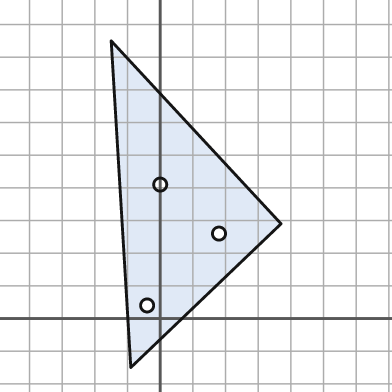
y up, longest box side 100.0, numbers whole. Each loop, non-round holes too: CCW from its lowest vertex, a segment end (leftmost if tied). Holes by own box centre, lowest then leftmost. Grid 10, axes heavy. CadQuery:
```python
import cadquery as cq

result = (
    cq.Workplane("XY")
    .moveTo(-9.0, -15.0)
    .lineTo(37.0, 29.0)
    .lineTo(-15.0, 85.0)
    .close()
    .moveTo(-4.0, 4.0)
    .circle(2.0)
    .moveTo(18.0, 26.0)
    .circle(2.0)
    .moveTo(0.0, 41.0)
    .circle(2.0)
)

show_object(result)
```